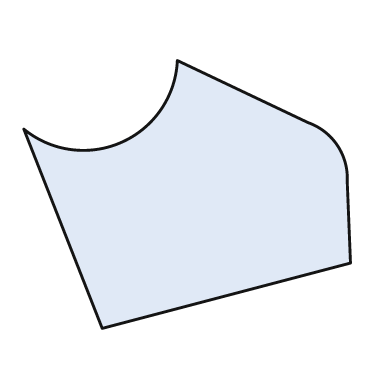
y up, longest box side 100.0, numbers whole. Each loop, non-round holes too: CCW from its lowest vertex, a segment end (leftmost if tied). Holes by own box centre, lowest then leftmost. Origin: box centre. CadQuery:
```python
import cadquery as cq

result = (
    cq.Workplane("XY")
    .moveTo(-26.0, -41.0)
    .lineTo(50.0, -21.0)
    .lineTo(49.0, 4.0)
    .threePointArc((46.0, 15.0), (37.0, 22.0))
    .lineTo(-3.0, 41.0)
    .threePointArc((-20.0, 16.0), (-50.0, 20.0))
    .close()
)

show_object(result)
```